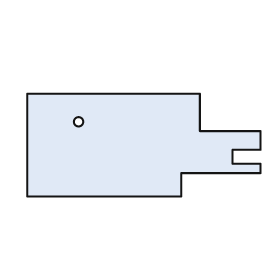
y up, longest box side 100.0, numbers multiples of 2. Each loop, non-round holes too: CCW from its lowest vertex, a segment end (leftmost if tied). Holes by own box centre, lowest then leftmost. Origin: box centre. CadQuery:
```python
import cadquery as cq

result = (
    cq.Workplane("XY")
    .moveTo(-50.0, -22.0)
    .lineTo(16.0, -22.0)
    .lineTo(16.0, -12.0)
    .lineTo(50.0, -12.0)
    .lineTo(50.0, -8.0)
    .lineTo(38.0, -8.0)
    .lineTo(38.0, -2.0)
    .lineTo(50.0, -2.0)
    .lineTo(50.0, 6.0)
    .lineTo(24.0, 6.0)
    .lineTo(24.0, 22.0)
    .lineTo(-50.0, 22.0)
    .close()
    .moveTo(-28.0, 10.0)
    .circle(2.0)
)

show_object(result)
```